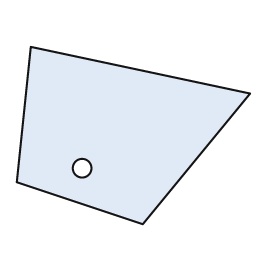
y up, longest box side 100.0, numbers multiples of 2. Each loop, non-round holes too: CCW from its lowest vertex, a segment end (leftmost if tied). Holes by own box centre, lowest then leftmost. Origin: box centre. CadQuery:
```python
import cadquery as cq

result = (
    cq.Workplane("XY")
    .moveTo(4.0, -38.0)
    .lineTo(50.0, 18.0)
    .lineTo(-44.0, 38.0)
    .lineTo(-50.0, -20.0)
    .close()
    .moveTo(-22.0, -14.0)
    .circle(4.0)
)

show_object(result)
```